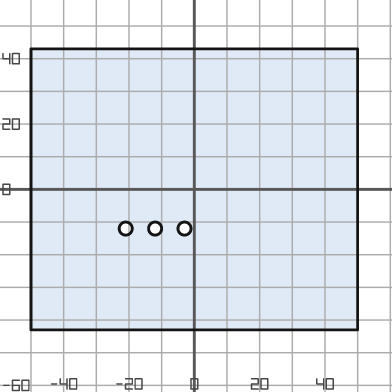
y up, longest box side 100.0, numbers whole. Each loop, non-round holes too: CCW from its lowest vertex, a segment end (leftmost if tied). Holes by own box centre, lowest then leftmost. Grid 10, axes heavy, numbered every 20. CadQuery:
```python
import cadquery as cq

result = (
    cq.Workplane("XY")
    .moveTo(-50.0, -43.0)
    .lineTo(50.0, -43.0)
    .lineTo(50.0, 43.0)
    .lineTo(-50.0, 43.0)
    .close()
    .moveTo(-21.0, -12.0)
    .circle(2.0)
    .moveTo(-12.0, -12.0)
    .circle(2.0)
    .moveTo(-3.0, -12.0)
    .circle(2.0)
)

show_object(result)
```